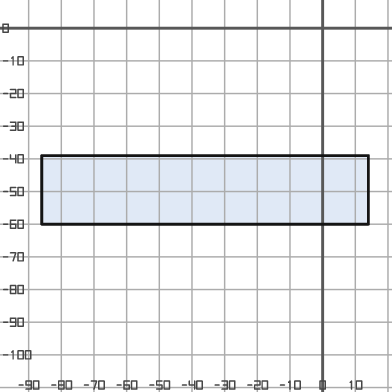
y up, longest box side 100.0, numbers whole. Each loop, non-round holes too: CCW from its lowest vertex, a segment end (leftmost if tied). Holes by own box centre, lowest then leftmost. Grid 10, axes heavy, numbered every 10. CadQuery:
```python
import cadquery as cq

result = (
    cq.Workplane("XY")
    .moveTo(-86.0, -60.0)
    .lineTo(14.0, -60.0)
    .lineTo(14.0, -39.0)
    .lineTo(-86.0, -39.0)
    .close()
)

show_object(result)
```